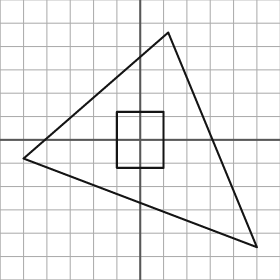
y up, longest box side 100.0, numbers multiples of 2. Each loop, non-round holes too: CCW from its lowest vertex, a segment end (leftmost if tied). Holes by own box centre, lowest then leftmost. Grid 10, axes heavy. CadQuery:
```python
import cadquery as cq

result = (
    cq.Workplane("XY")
    .moveTo(50.0, -46.0)
    .lineTo(12.0, 46.0)
    .lineTo(-50.0, -8.0)
    .close()
    .moveTo(-10.0, -12.0)
    .lineTo(10.0, -12.0)
    .lineTo(10.0, 12.0)
    .lineTo(-10.0, 12.0)
    .close()
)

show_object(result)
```